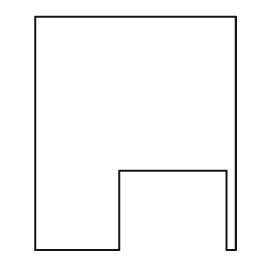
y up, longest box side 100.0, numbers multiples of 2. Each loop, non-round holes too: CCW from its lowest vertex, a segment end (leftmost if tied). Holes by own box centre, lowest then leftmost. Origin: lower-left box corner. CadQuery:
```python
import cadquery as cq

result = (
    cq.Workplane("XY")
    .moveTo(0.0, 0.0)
    .lineTo(36.0, 0.0)
    .lineTo(36.0, 34.0)
    .lineTo(82.0, 34.0)
    .lineTo(82.0, 0.0)
    .lineTo(86.0, 0.0)
    .lineTo(86.0, 100.0)
    .lineTo(0.0, 100.0)
    .close()
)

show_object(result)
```